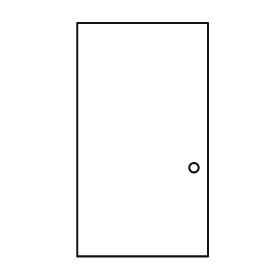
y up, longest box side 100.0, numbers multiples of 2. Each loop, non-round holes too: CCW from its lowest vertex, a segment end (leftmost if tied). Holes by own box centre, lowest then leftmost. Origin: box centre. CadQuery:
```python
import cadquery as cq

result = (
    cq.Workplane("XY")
    .moveTo(-28.0, -50.0)
    .lineTo(28.0, -50.0)
    .lineTo(28.0, 50.0)
    .lineTo(-28.0, 50.0)
    .close()
    .moveTo(22.0, -12.0)
    .circle(2.0)
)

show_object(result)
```